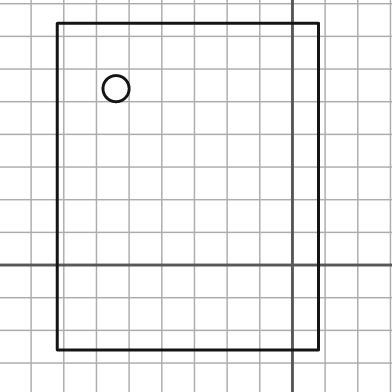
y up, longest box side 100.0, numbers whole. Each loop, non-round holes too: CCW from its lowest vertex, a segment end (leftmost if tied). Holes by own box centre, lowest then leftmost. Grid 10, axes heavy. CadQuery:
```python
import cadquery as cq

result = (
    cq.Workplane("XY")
    .moveTo(-72.0, -26.0)
    .lineTo(8.0, -26.0)
    .lineTo(8.0, 74.0)
    .lineTo(-72.0, 74.0)
    .close()
    .moveTo(-54.0, 54.0)
    .circle(4.0)
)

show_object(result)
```